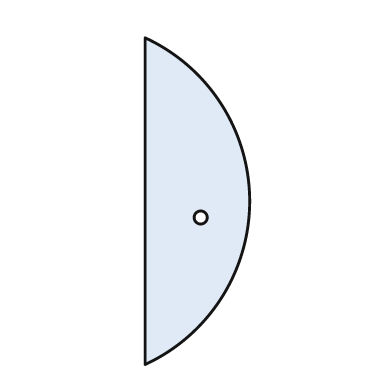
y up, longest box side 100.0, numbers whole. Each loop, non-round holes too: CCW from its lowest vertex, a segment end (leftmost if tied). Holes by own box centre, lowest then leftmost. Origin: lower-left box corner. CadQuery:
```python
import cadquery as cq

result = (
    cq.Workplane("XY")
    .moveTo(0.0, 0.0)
    .threePointArc((32.0, 50.0), (0.0, 100.0))
    .close()
    .moveTo(17.0, 45.0)
    .circle(2.0)
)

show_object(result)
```